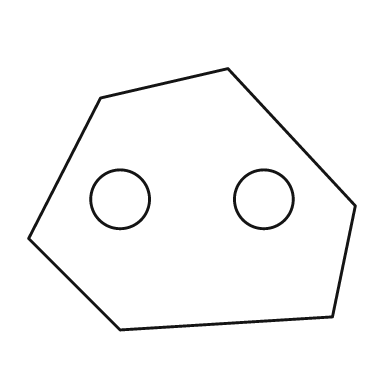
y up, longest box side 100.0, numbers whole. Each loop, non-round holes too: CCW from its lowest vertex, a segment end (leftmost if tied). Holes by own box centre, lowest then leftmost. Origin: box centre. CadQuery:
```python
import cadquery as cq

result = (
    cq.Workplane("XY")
    .moveTo(-22.0, -40.0)
    .lineTo(43.0, -36.0)
    .lineTo(50.0, -2.0)
    .lineTo(11.0, 40.0)
    .lineTo(-28.0, 31.0)
    .lineTo(-50.0, -12.0)
    .close()
    .moveTo(-22.0, 0.0)
    .circle(9.0)
    .moveTo(22.0, 0.0)
    .circle(9.0)
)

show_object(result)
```